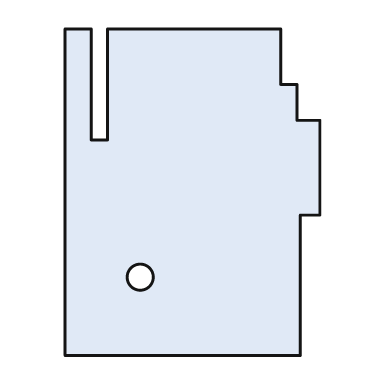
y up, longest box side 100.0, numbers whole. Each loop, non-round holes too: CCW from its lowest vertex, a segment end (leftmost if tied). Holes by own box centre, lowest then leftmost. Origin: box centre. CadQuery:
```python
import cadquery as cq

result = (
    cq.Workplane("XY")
    .moveTo(-39.0, -50.0)
    .lineTo(33.0, -50.0)
    .lineTo(33.0, -7.0)
    .lineTo(39.0, -7.0)
    .lineTo(39.0, 22.0)
    .lineTo(32.0, 22.0)
    .lineTo(32.0, 33.0)
    .lineTo(27.0, 33.0)
    .lineTo(27.0, 50.0)
    .lineTo(-26.0, 50.0)
    .lineTo(-26.0, 16.0)
    .lineTo(-31.0, 16.0)
    .lineTo(-31.0, 50.0)
    .lineTo(-39.0, 50.0)
    .close()
    .moveTo(-16.0, -26.0)
    .circle(4.0)
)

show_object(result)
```